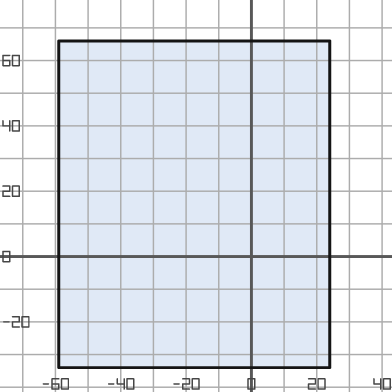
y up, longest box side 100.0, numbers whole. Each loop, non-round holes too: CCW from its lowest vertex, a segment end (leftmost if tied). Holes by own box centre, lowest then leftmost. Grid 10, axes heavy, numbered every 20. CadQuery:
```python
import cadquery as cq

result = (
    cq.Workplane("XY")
    .moveTo(-59.0, -34.0)
    .lineTo(24.0, -34.0)
    .lineTo(24.0, 66.0)
    .lineTo(-59.0, 66.0)
    .close()
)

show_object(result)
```